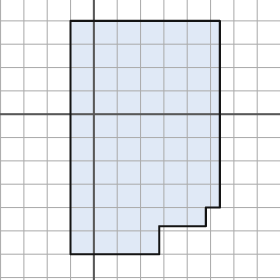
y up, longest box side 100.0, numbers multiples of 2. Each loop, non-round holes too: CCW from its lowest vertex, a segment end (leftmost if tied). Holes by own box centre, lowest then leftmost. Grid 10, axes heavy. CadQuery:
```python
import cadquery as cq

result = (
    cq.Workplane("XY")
    .moveTo(-10.0, -60.0)
    .lineTo(28.0, -60.0)
    .lineTo(28.0, -48.0)
    .lineTo(48.0, -48.0)
    .lineTo(48.0, -40.0)
    .lineTo(54.0, -40.0)
    .lineTo(54.0, 40.0)
    .lineTo(-10.0, 40.0)
    .close()
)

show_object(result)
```